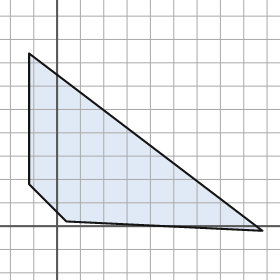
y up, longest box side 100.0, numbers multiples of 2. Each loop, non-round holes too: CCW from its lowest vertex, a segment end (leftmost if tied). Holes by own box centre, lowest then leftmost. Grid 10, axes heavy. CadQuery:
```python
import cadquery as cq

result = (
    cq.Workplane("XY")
    .moveTo(88.0, -2.0)
    .lineTo(-12.0, 74.0)
    .lineTo(-12.0, 18.0)
    .lineTo(4.0, 2.0)
    .close()
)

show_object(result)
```